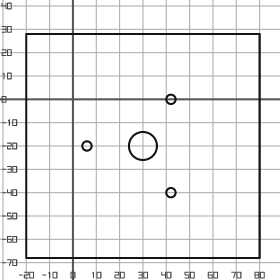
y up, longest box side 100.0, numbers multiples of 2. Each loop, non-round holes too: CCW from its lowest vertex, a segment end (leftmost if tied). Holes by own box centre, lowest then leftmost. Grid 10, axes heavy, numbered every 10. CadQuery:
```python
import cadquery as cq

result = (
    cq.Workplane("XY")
    .moveTo(-20.0, -68.0)
    .lineTo(80.0, -68.0)
    .lineTo(80.0, 28.0)
    .lineTo(-20.0, 28.0)
    .close()
    .moveTo(42.0, -40.0)
    .circle(2.0)
    .moveTo(6.0, -20.0)
    .circle(2.0)
    .moveTo(30.0, -20.0)
    .circle(6.0)
    .moveTo(42.0, 0.0)
    .circle(2.0)
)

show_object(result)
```